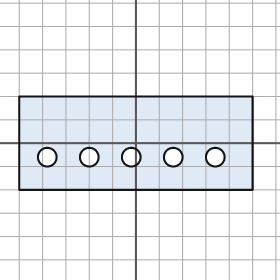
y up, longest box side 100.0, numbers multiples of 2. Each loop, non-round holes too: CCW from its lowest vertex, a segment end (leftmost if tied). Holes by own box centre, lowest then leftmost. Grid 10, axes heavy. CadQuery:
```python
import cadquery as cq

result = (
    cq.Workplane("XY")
    .moveTo(-50.0, -20.0)
    .lineTo(50.0, -20.0)
    .lineTo(50.0, 20.0)
    .lineTo(-50.0, 20.0)
    .close()
    .moveTo(-38.0, -6.0)
    .circle(4.0)
    .moveTo(-20.0, -6.0)
    .circle(4.0)
    .moveTo(-2.0, -6.0)
    .circle(4.0)
    .moveTo(16.0, -6.0)
    .circle(4.0)
    .moveTo(34.0, -6.0)
    .circle(4.0)
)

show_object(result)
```